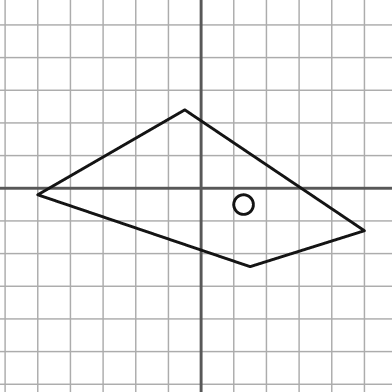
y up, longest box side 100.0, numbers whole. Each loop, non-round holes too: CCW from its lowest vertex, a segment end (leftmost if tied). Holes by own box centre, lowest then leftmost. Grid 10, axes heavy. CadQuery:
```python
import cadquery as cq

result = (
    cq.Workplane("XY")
    .moveTo(15.0, -24.0)
    .lineTo(50.0, -13.0)
    .lineTo(-5.0, 24.0)
    .lineTo(-50.0, -2.0)
    .close()
    .moveTo(13.0, -5.0)
    .circle(3.0)
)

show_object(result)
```